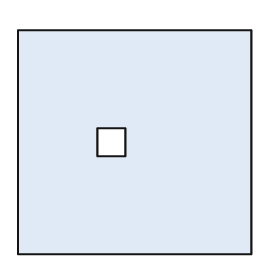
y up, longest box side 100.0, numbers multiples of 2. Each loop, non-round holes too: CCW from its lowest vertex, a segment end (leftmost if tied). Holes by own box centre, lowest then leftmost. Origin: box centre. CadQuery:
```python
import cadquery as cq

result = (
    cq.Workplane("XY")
    .moveTo(-50.0, -48.0)
    .lineTo(50.0, -48.0)
    .lineTo(50.0, 48.0)
    .lineTo(-50.0, 48.0)
    .close()
    .moveTo(-16.0, -6.0)
    .lineTo(-4.0, -6.0)
    .lineTo(-4.0, 6.0)
    .lineTo(-16.0, 6.0)
    .close()
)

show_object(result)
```